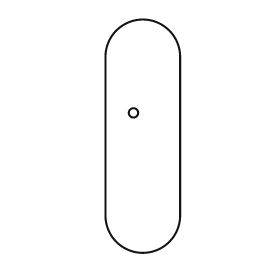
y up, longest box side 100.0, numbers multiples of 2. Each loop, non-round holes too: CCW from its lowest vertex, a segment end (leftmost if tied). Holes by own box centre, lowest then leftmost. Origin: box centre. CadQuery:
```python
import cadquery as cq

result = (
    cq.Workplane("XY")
    .moveTo(-16.0, -34.0)
    .threePointArc((0.0, -50.0), (16.0, -34.0))
    .lineTo(16.0, 34.0)
    .threePointArc((0.0, 50.0), (-16.0, 34.0))
    .close()
    .moveTo(-4.0, 10.0)
    .circle(2.0)
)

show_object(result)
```